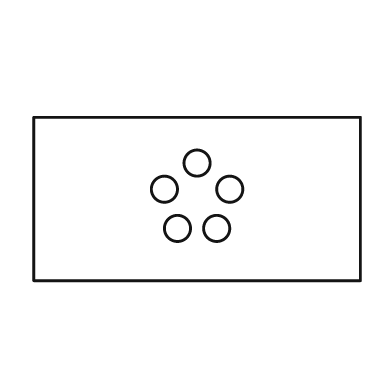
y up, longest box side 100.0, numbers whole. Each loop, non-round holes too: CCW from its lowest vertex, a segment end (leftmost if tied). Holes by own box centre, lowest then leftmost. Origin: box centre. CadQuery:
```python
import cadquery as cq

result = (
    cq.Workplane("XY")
    .moveTo(-50.0, -25.0)
    .lineTo(50.0, -25.0)
    .lineTo(50.0, 25.0)
    .lineTo(-50.0, 25.0)
    .close()
    .moveTo(-6.0, -9.0)
    .circle(4.0)
    .moveTo(6.0, -9.0)
    .circle(4.0)
    .moveTo(-10.0, 3.0)
    .circle(4.0)
    .moveTo(10.0, 3.0)
    .circle(4.0)
    .moveTo(0.0, 11.0)
    .circle(4.0)
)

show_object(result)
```